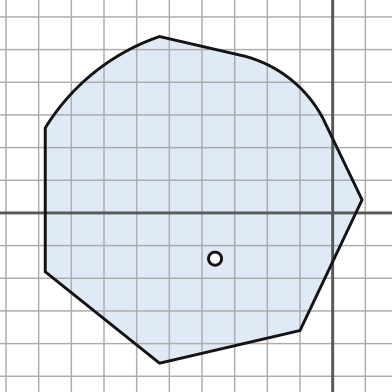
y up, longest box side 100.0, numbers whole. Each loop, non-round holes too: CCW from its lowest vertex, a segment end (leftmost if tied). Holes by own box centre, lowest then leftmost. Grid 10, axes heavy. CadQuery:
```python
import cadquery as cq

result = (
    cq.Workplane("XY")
    .moveTo(-53.0, -46.0)
    .lineTo(-10.0, -36.0)
    .lineTo(9.0, 4.0)
    .lineTo(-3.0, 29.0)
    .threePointArc((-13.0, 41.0), (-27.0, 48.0))
    .lineTo(-53.0, 54.0)
    .threePointArc((-73.0, 43.0), (-88.0, 26.0))
    .lineTo(-88.0, -18.0)
    .close()
    .moveTo(-36.0, -14.0)
    .circle(2.0)
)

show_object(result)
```